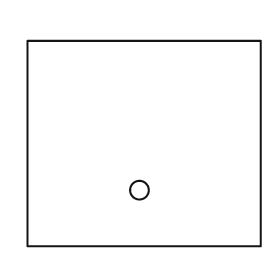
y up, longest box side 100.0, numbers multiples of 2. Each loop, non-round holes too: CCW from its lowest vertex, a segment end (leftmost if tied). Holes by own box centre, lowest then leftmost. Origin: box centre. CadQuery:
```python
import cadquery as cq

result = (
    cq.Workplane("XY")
    .moveTo(-50.0, -44.0)
    .lineTo(50.0, -44.0)
    .lineTo(50.0, 44.0)
    .lineTo(-50.0, 44.0)
    .close()
    .moveTo(-2.0, -20.0)
    .circle(4.0)
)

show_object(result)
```